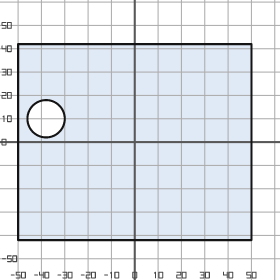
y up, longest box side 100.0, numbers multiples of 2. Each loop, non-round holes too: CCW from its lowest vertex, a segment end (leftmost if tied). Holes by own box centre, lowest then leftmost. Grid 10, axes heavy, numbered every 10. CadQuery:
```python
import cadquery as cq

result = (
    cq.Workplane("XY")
    .moveTo(-50.0, -42.0)
    .lineTo(50.0, -42.0)
    .lineTo(50.0, 42.0)
    .lineTo(-50.0, 42.0)
    .close()
    .moveTo(-38.0, 10.0)
    .circle(8.0)
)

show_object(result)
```